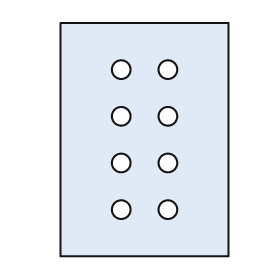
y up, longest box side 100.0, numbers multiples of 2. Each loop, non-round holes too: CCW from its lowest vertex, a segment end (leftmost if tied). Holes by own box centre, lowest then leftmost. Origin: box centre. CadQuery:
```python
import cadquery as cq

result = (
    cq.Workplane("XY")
    .moveTo(-36.0, -50.0)
    .lineTo(36.0, -50.0)
    .lineTo(36.0, 50.0)
    .lineTo(-36.0, 50.0)
    .close()
    .moveTo(-10.0, -30.0)
    .circle(4.0)
    .moveTo(10.0, -30.0)
    .circle(4.0)
    .moveTo(-10.0, -10.0)
    .circle(4.0)
    .moveTo(10.0, -10.0)
    .circle(4.0)
    .moveTo(-10.0, 10.0)
    .circle(4.0)
    .moveTo(10.0, 10.0)
    .circle(4.0)
    .moveTo(-10.0, 30.0)
    .circle(4.0)
    .moveTo(10.0, 30.0)
    .circle(4.0)
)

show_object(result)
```